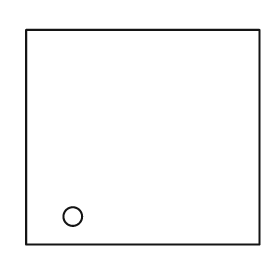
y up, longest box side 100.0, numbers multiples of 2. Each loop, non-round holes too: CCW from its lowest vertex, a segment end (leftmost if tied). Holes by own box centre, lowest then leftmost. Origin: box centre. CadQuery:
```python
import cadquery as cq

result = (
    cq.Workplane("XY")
    .moveTo(-50.0, -46.0)
    .lineTo(50.0, -46.0)
    .lineTo(50.0, 46.0)
    .lineTo(-50.0, 46.0)
    .close()
    .moveTo(-30.0, -34.0)
    .circle(4.0)
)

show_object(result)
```